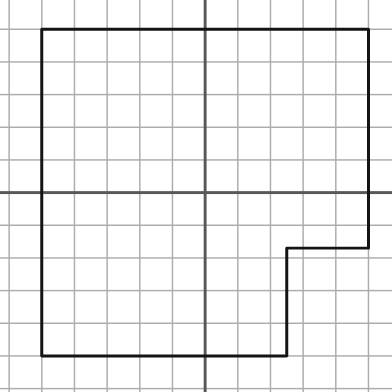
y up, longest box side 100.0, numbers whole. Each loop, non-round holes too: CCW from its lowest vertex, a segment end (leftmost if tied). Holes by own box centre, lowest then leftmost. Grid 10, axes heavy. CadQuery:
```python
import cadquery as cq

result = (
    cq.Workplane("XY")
    .moveTo(-50.0, -50.0)
    .lineTo(25.0, -50.0)
    .lineTo(25.0, -17.0)
    .lineTo(50.0, -17.0)
    .lineTo(50.0, 50.0)
    .lineTo(-50.0, 50.0)
    .close()
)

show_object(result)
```